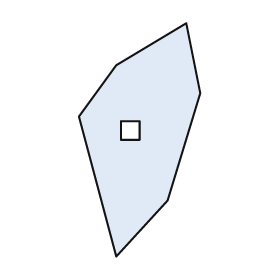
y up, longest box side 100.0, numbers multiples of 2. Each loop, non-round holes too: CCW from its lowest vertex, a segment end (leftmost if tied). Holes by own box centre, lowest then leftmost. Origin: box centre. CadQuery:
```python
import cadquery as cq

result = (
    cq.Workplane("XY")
    .moveTo(-10.0, -50.0)
    .lineTo(12.0, -26.0)
    .lineTo(26.0, 20.0)
    .lineTo(20.0, 50.0)
    .lineTo(-10.0, 32.0)
    .lineTo(-26.0, 10.0)
    .close()
    .moveTo(-8.0, 0.0)
    .lineTo(0.0, 0.0)
    .lineTo(0.0, 8.0)
    .lineTo(-8.0, 8.0)
    .close()
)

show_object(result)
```